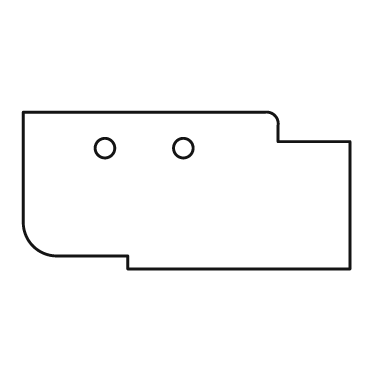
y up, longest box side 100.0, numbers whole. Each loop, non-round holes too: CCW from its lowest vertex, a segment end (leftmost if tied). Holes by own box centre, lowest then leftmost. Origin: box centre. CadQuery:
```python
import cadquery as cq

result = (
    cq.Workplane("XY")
    .moveTo(-18.0, -24.0)
    .lineTo(50.0, -24.0)
    .lineTo(50.0, 15.0)
    .lineTo(28.0, 15.0)
    .lineTo(28.0, 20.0)
    .threePointArc((27.0, 23.0), (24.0, 24.0))
    .lineTo(-50.0, 24.0)
    .lineTo(-50.0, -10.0)
    .threePointArc((-47.0, -17.0), (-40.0, -20.0))
    .lineTo(-18.0, -20.0)
    .close()
    .moveTo(-25.0, 13.0)
    .circle(3.0)
    .moveTo(-1.0, 13.0)
    .circle(3.0)
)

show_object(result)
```